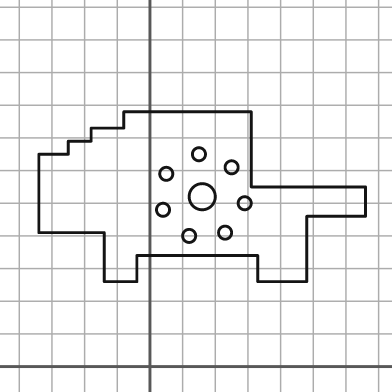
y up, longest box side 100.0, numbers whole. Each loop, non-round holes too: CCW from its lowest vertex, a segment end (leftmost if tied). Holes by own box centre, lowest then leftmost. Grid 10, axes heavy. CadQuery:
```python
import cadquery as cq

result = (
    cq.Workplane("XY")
    .moveTo(-14.0, 26.0)
    .lineTo(-4.0, 26.0)
    .lineTo(-4.0, 34.0)
    .lineTo(33.0, 34.0)
    .lineTo(33.0, 26.0)
    .lineTo(48.0, 26.0)
    .lineTo(48.0, 46.0)
    .lineTo(66.0, 46.0)
    .lineTo(66.0, 55.0)
    .lineTo(31.0, 55.0)
    .lineTo(31.0, 78.0)
    .lineTo(-8.0, 78.0)
    .lineTo(-8.0, 73.0)
    .lineTo(-18.0, 73.0)
    .lineTo(-18.0, 69.0)
    .lineTo(-25.0, 69.0)
    .lineTo(-25.0, 65.0)
    .lineTo(-34.0, 65.0)
    .lineTo(-34.0, 41.0)
    .lineTo(-14.0, 41.0)
    .close()
    .moveTo(12.0, 40.0)
    .circle(2.0)
    .moveTo(23.0, 41.0)
    .circle(2.0)
    .moveTo(4.0, 48.0)
    .circle(2.0)
    .moveTo(29.0, 50.0)
    .circle(2.0)
    .moveTo(16.0, 52.0)
    .circle(4.0)
    .moveTo(5.0, 59.0)
    .circle(2.0)
    .moveTo(25.0, 61.0)
    .circle(2.0)
    .moveTo(15.0, 65.0)
    .circle(2.0)
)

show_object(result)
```